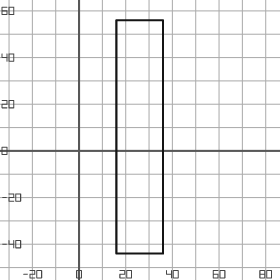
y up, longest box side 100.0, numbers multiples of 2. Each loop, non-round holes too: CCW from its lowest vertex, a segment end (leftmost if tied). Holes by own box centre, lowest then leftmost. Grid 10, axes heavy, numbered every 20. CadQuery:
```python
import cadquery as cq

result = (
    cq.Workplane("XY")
    .moveTo(16.0, -44.0)
    .lineTo(36.0, -44.0)
    .lineTo(36.0, 56.0)
    .lineTo(16.0, 56.0)
    .close()
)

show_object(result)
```